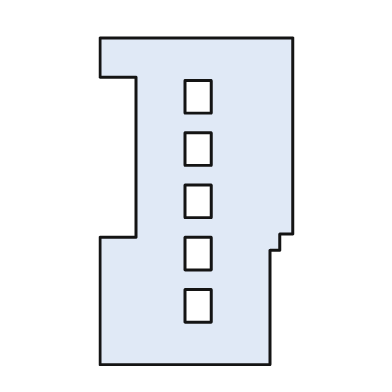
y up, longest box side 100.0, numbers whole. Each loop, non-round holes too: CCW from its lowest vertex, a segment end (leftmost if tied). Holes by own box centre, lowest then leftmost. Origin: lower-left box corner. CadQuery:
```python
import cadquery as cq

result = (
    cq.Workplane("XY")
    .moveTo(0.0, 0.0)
    .lineTo(52.0, 0.0)
    .lineTo(52.0, 35.0)
    .lineTo(55.0, 35.0)
    .lineTo(55.0, 40.0)
    .lineTo(59.0, 40.0)
    .lineTo(59.0, 100.0)
    .lineTo(0.0, 100.0)
    .lineTo(0.0, 88.0)
    .lineTo(11.0, 88.0)
    .lineTo(11.0, 39.0)
    .lineTo(0.0, 39.0)
    .close()
    .moveTo(26.0, 13.0)
    .lineTo(34.0, 13.0)
    .lineTo(34.0, 23.0)
    .lineTo(26.0, 23.0)
    .close()
    .moveTo(26.0, 29.0)
    .lineTo(34.0, 29.0)
    .lineTo(34.0, 39.0)
    .lineTo(26.0, 39.0)
    .close()
    .moveTo(26.0, 45.0)
    .lineTo(34.0, 45.0)
    .lineTo(34.0, 55.0)
    .lineTo(26.0, 55.0)
    .close()
    .moveTo(26.0, 61.0)
    .lineTo(34.0, 61.0)
    .lineTo(34.0, 71.0)
    .lineTo(26.0, 71.0)
    .close()
    .moveTo(26.0, 77.0)
    .lineTo(34.0, 77.0)
    .lineTo(34.0, 87.0)
    .lineTo(26.0, 87.0)
    .close()
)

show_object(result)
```